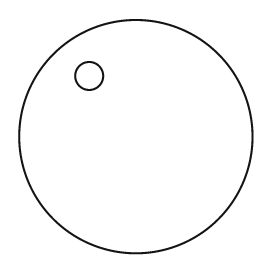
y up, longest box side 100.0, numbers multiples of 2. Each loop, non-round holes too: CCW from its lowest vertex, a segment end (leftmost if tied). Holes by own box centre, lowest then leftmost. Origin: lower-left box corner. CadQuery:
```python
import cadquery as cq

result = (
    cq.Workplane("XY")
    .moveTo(50.0, 50.0)
    .circle(50.0)
    .moveTo(30.0, 76.0)
    .circle(6.0)
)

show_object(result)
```